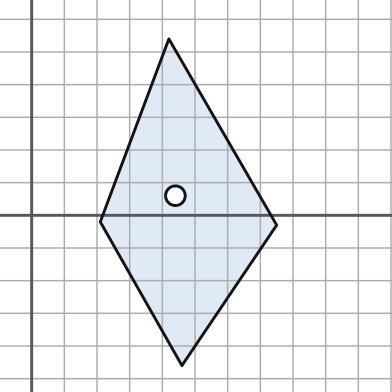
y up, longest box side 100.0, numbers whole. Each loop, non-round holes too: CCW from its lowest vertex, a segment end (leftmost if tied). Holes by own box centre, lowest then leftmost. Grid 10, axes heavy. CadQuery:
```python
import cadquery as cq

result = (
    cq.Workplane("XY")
    .moveTo(46.0, -46.0)
    .lineTo(75.0, -3.0)
    .lineTo(42.0, 54.0)
    .lineTo(21.0, -2.0)
    .close()
    .moveTo(44.0, 6.0)
    .circle(3.0)
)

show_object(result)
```